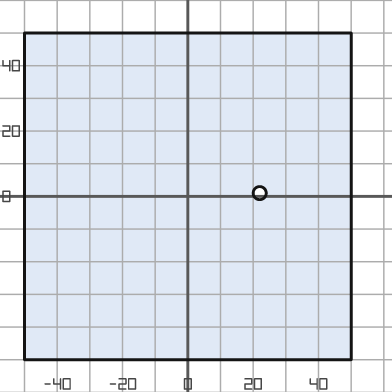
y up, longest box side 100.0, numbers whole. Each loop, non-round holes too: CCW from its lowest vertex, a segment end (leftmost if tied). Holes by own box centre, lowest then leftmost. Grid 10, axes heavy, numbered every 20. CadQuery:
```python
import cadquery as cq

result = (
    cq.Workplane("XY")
    .moveTo(-50.0, -50.0)
    .lineTo(50.0, -50.0)
    .lineTo(50.0, 50.0)
    .lineTo(-50.0, 50.0)
    .close()
    .moveTo(22.0, 1.0)
    .circle(2.0)
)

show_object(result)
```